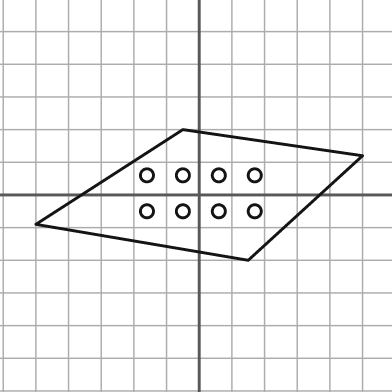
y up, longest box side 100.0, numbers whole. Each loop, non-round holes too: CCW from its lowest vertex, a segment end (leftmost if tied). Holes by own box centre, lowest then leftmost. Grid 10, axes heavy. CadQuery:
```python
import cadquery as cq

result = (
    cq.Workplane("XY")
    .moveTo(15.0, -20.0)
    .lineTo(50.0, 12.0)
    .lineTo(-5.0, 20.0)
    .lineTo(-50.0, -9.0)
    .close()
    .moveTo(-16.0, -5.0)
    .circle(2.0)
    .moveTo(-5.0, -5.0)
    .circle(2.0)
    .moveTo(6.0, -5.0)
    .circle(2.0)
    .moveTo(17.0, -5.0)
    .circle(2.0)
    .moveTo(-16.0, 6.0)
    .circle(2.0)
    .moveTo(-5.0, 6.0)
    .circle(2.0)
    .moveTo(6.0, 6.0)
    .circle(2.0)
    .moveTo(17.0, 6.0)
    .circle(2.0)
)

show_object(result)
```